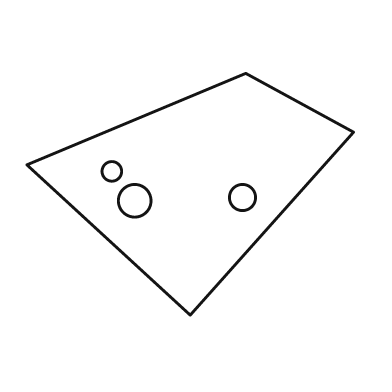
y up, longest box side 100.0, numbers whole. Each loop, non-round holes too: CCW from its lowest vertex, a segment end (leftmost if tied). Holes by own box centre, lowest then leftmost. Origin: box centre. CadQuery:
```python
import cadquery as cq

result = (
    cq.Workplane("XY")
    .moveTo(0.0, -37.0)
    .lineTo(50.0, 19.0)
    .lineTo(17.0, 37.0)
    .lineTo(-50.0, 9.0)
    .close()
    .moveTo(-17.0, -2.0)
    .circle(5.0)
    .moveTo(16.0, -1.0)
    .circle(4.0)
    .moveTo(-24.0, 7.0)
    .circle(3.0)
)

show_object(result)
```